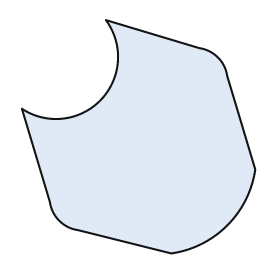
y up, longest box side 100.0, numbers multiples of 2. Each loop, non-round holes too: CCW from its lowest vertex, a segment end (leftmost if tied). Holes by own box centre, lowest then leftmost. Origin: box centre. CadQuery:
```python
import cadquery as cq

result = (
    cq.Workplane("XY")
    .moveTo(14.0, -50.0)
    .threePointArc((38.0, -38.0), (50.0, -14.0))
    .lineTo(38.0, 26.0)
    .threePointArc((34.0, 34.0), (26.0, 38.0))
    .lineTo(-14.0, 50.0)
    .threePointArc((-16.0, 16.0), (-50.0, 12.0))
    .lineTo(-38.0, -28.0)
    .threePointArc((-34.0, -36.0), (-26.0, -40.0))
    .close()
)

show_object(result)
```